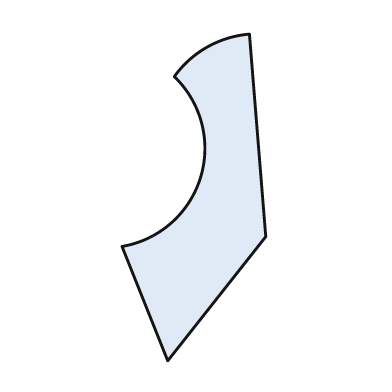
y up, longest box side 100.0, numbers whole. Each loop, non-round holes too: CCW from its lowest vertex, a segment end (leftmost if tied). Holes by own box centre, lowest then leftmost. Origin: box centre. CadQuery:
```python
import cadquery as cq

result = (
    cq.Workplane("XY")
    .moveTo(-8.0, -50.0)
    .lineTo(22.0, -12.0)
    .lineTo(17.0, 50.0)
    .threePointArc((4.0, 46.0), (-6.0, 37.0))
    .threePointArc((2.0, 6.0), (-22.0, -15.0))
    .close()
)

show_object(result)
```